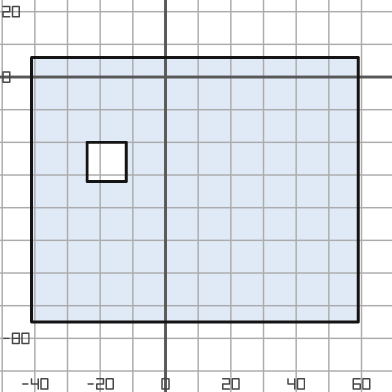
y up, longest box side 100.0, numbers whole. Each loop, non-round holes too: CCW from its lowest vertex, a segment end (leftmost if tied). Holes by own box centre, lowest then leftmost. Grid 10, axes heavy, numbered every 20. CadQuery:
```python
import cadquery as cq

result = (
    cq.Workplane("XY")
    .moveTo(-41.0, -75.0)
    .lineTo(59.0, -75.0)
    .lineTo(59.0, 6.0)
    .lineTo(-41.0, 6.0)
    .close()
    .moveTo(-24.0, -32.0)
    .lineTo(-12.0, -32.0)
    .lineTo(-12.0, -20.0)
    .lineTo(-24.0, -20.0)
    .close()
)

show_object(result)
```